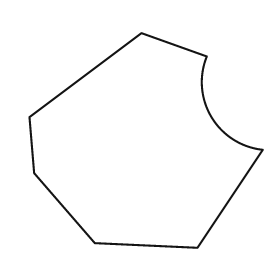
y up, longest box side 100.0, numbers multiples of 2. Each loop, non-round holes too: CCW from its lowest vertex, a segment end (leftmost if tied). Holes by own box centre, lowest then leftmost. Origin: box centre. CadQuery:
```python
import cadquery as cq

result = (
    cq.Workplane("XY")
    .moveTo(22.0, -46.0)
    .lineTo(50.0, -4.0)
    .threePointArc((28.0, 10.0), (26.0, 36.0))
    .lineTo(-2.0, 46.0)
    .lineTo(-50.0, 10.0)
    .lineTo(-48.0, -14.0)
    .lineTo(-22.0, -44.0)
    .close()
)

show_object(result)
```